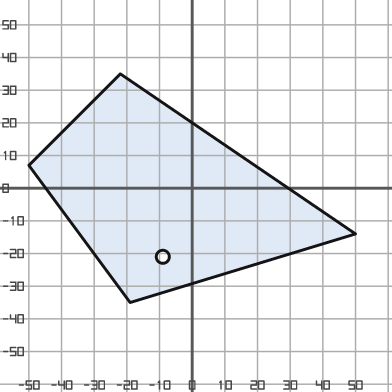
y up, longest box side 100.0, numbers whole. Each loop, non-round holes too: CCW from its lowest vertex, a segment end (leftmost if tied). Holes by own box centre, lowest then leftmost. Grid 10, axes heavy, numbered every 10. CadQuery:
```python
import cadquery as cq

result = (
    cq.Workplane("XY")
    .moveTo(-19.0, -35.0)
    .lineTo(50.0, -14.0)
    .lineTo(-22.0, 35.0)
    .lineTo(-50.0, 7.0)
    .close()
    .moveTo(-9.0, -21.0)
    .circle(2.0)
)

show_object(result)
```